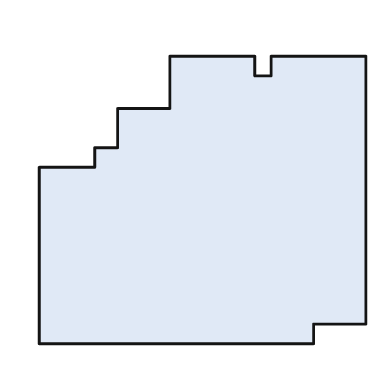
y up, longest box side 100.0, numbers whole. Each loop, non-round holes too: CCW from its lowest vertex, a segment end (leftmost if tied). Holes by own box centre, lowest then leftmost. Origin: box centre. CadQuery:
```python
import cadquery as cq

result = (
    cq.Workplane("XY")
    .moveTo(-50.0, -44.0)
    .lineTo(34.0, -44.0)
    .lineTo(34.0, -38.0)
    .lineTo(50.0, -38.0)
    .lineTo(50.0, 44.0)
    .lineTo(21.0, 44.0)
    .lineTo(21.0, 38.0)
    .lineTo(16.0, 38.0)
    .lineTo(16.0, 44.0)
    .lineTo(-10.0, 44.0)
    .lineTo(-10.0, 28.0)
    .lineTo(-26.0, 28.0)
    .lineTo(-26.0, 16.0)
    .lineTo(-33.0, 16.0)
    .lineTo(-33.0, 10.0)
    .lineTo(-50.0, 10.0)
    .close()
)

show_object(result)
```